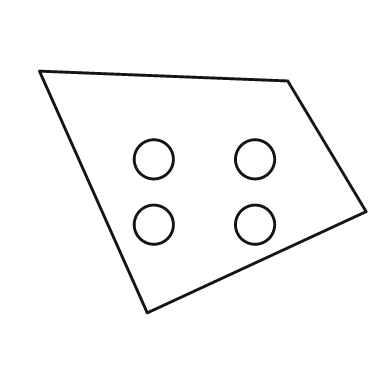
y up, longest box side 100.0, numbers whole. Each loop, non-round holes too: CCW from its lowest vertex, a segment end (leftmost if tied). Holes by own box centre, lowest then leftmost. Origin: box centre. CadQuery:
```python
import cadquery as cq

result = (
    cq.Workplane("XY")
    .moveTo(-17.0, -37.0)
    .lineTo(50.0, -6.0)
    .lineTo(26.0, 34.0)
    .lineTo(-50.0, 37.0)
    .close()
    .moveTo(-15.0, -10.0)
    .circle(6.0)
    .moveTo(16.0, -10.0)
    .circle(6.0)
    .moveTo(-15.0, 10.0)
    .circle(6.0)
    .moveTo(16.0, 10.0)
    .circle(6.0)
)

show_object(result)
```